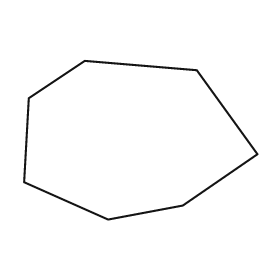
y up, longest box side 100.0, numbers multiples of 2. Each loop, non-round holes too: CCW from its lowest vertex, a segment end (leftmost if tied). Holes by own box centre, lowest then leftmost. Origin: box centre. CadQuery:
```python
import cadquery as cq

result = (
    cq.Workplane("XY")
    .moveTo(-14.0, -34.0)
    .lineTo(18.0, -28.0)
    .lineTo(50.0, -6.0)
    .lineTo(24.0, 30.0)
    .lineTo(-24.0, 34.0)
    .lineTo(-48.0, 18.0)
    .lineTo(-50.0, -18.0)
    .close()
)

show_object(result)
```